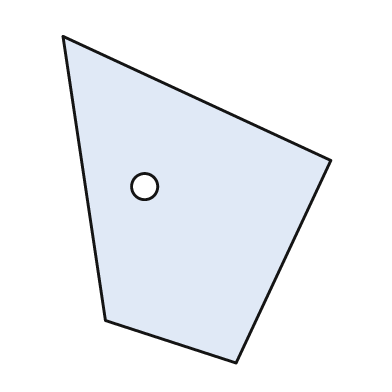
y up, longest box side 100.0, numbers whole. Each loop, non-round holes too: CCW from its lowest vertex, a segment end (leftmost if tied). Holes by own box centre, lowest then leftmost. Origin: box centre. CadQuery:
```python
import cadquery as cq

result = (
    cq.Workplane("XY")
    .moveTo(12.0, -50.0)
    .lineTo(41.0, 12.0)
    .lineTo(-41.0, 50.0)
    .lineTo(-28.0, -37.0)
    .close()
    .moveTo(-16.0, 4.0)
    .circle(4.0)
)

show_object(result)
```